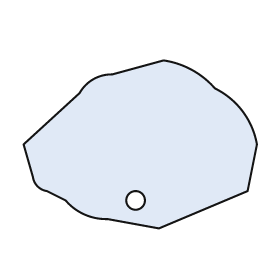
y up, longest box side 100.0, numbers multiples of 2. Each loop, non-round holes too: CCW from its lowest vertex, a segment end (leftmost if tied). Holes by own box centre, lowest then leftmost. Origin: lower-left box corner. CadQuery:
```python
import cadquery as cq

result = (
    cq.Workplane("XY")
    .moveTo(58.0, 0.0)
    .lineTo(96.0, 16.0)
    .lineTo(100.0, 36.0)
    .threePointArc((94.0, 50.0), (82.0, 60.0))
    .threePointArc((72.0, 68.0), (60.0, 72.0))
    .lineTo(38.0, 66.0)
    .threePointArc((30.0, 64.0), (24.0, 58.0))
    .lineTo(0.0, 36.0)
    .lineTo(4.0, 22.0)
    .threePointArc((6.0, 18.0), (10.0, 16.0))
    .lineTo(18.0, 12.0)
    .threePointArc((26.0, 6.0), (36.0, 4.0))
    .close()
    .moveTo(48.0, 12.0)
    .circle(4.0)
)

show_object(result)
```